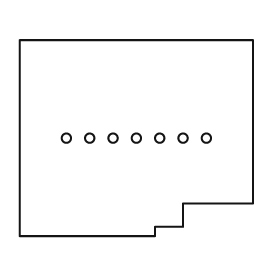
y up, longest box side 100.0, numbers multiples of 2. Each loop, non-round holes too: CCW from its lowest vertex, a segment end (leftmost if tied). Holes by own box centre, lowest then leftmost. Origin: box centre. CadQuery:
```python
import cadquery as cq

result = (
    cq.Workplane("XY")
    .moveTo(-50.0, -42.0)
    .lineTo(8.0, -42.0)
    .lineTo(8.0, -38.0)
    .lineTo(20.0, -38.0)
    .lineTo(20.0, -28.0)
    .lineTo(50.0, -28.0)
    .lineTo(50.0, 42.0)
    .lineTo(-50.0, 42.0)
    .close()
    .moveTo(-30.0, 0.0)
    .circle(2.0)
    .moveTo(-20.0, 0.0)
    .circle(2.0)
    .moveTo(-10.0, 0.0)
    .circle(2.0)
    .moveTo(0.0, 0.0)
    .circle(2.0)
    .moveTo(10.0, 0.0)
    .circle(2.0)
    .moveTo(20.0, 0.0)
    .circle(2.0)
    .moveTo(30.0, 0.0)
    .circle(2.0)
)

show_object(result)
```